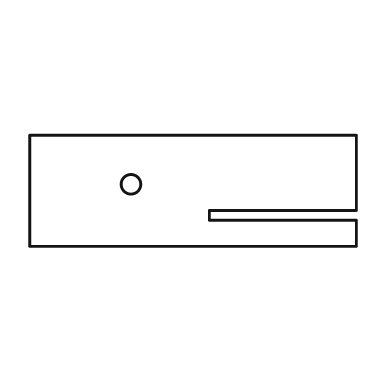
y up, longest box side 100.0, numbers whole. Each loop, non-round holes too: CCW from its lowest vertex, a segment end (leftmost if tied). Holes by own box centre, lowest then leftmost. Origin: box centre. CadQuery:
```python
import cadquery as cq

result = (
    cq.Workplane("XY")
    .moveTo(-50.0, -17.0)
    .lineTo(50.0, -17.0)
    .lineTo(50.0, -9.0)
    .lineTo(5.0, -9.0)
    .lineTo(5.0, -6.0)
    .lineTo(50.0, -6.0)
    .lineTo(50.0, 17.0)
    .lineTo(-50.0, 17.0)
    .close()
    .moveTo(-19.0, 2.0)
    .circle(3.0)
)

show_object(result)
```